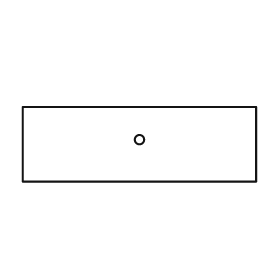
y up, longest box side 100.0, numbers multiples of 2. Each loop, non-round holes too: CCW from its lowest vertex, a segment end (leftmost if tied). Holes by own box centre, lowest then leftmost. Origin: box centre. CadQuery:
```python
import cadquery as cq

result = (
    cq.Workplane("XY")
    .moveTo(-50.0, -16.0)
    .lineTo(50.0, -16.0)
    .lineTo(50.0, 16.0)
    .lineTo(-50.0, 16.0)
    .close()
    .moveTo(0.0, 2.0)
    .circle(2.0)
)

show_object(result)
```